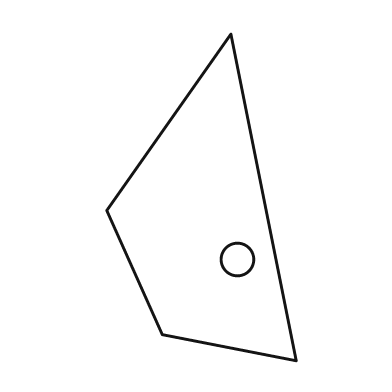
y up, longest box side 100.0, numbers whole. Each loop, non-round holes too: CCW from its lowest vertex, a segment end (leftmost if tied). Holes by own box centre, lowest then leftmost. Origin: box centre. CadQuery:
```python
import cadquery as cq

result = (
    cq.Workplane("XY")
    .moveTo(29.0, -50.0)
    .lineTo(9.0, 50.0)
    .lineTo(-29.0, -4.0)
    .lineTo(-12.0, -42.0)
    .close()
    .moveTo(11.0, -19.0)
    .circle(5.0)
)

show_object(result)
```